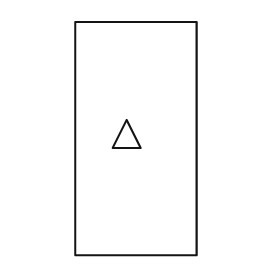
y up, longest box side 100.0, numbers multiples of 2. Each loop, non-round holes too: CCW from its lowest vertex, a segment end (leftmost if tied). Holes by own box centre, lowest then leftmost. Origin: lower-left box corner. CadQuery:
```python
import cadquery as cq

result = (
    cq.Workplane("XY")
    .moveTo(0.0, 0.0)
    .lineTo(52.0, 0.0)
    .lineTo(52.0, 100.0)
    .lineTo(0.0, 100.0)
    .close()
    .moveTo(16.0, 46.0)
    .lineTo(28.0, 46.0)
    .lineTo(22.0, 58.0)
    .close()
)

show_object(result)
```